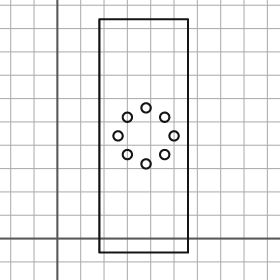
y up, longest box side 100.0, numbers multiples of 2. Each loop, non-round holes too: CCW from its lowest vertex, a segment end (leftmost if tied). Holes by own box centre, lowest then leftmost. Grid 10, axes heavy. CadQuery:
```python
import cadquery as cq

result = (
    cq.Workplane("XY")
    .moveTo(18.0, -6.0)
    .lineTo(56.0, -6.0)
    .lineTo(56.0, 94.0)
    .lineTo(18.0, 94.0)
    .close()
    .moveTo(38.0, 32.0)
    .circle(2.0)
    .moveTo(30.0, 36.0)
    .circle(2.0)
    .moveTo(46.0, 36.0)
    .circle(2.0)
    .moveTo(26.0, 44.0)
    .circle(2.0)
    .moveTo(50.0, 44.0)
    .circle(2.0)
    .moveTo(30.0, 52.0)
    .circle(2.0)
    .moveTo(46.0, 52.0)
    .circle(2.0)
    .moveTo(38.0, 56.0)
    .circle(2.0)
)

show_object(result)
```